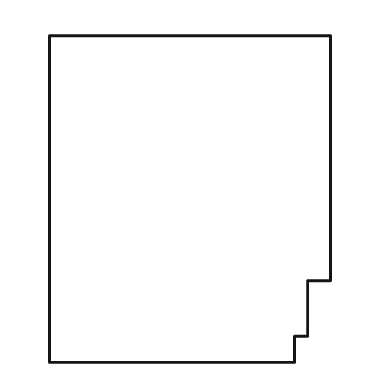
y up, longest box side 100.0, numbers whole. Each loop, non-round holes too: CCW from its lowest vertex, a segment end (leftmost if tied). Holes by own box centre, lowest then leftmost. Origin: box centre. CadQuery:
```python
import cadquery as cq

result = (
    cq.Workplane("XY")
    .moveTo(-43.0, -50.0)
    .lineTo(32.0, -50.0)
    .lineTo(32.0, -42.0)
    .lineTo(36.0, -42.0)
    .lineTo(36.0, -25.0)
    .lineTo(43.0, -25.0)
    .lineTo(43.0, 50.0)
    .lineTo(-43.0, 50.0)
    .close()
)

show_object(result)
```